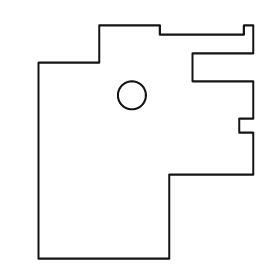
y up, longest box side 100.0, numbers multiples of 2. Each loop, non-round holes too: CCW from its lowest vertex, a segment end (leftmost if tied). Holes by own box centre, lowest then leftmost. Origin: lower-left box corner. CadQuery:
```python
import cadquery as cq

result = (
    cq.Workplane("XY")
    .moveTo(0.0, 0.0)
    .lineTo(56.0, 0.0)
    .lineTo(56.0, 36.0)
    .lineTo(92.0, 36.0)
    .lineTo(92.0, 54.0)
    .lineTo(86.0, 54.0)
    .lineTo(86.0, 60.0)
    .lineTo(92.0, 60.0)
    .lineTo(92.0, 76.0)
    .lineTo(66.0, 76.0)
    .lineTo(66.0, 88.0)
    .lineTo(92.0, 88.0)
    .lineTo(92.0, 100.0)
    .lineTo(88.0, 100.0)
    .lineTo(88.0, 96.0)
    .lineTo(52.0, 96.0)
    .lineTo(52.0, 100.0)
    .lineTo(26.0, 100.0)
    .lineTo(26.0, 84.0)
    .lineTo(0.0, 84.0)
    .close()
    .moveTo(40.0, 70.0)
    .circle(6.0)
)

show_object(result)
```